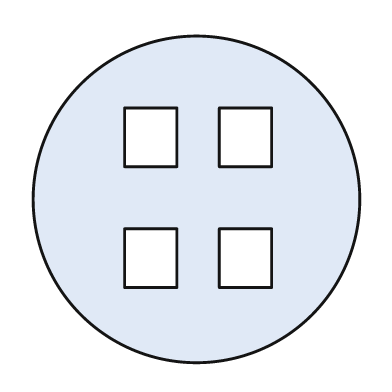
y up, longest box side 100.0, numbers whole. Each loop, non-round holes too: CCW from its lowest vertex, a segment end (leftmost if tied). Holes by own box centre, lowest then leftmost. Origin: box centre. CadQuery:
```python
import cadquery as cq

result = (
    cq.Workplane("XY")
    .moveTo(0.0, 0.0)
    .circle(50.0)
    .moveTo(-22.0, -27.0)
    .lineTo(-6.0, -27.0)
    .lineTo(-6.0, -9.0)
    .lineTo(-22.0, -9.0)
    .close()
    .moveTo(7.0, -27.0)
    .lineTo(23.0, -27.0)
    .lineTo(23.0, -9.0)
    .lineTo(7.0, -9.0)
    .close()
    .moveTo(-22.0, 10.0)
    .lineTo(-6.0, 10.0)
    .lineTo(-6.0, 28.0)
    .lineTo(-22.0, 28.0)
    .close()
    .moveTo(7.0, 10.0)
    .lineTo(23.0, 10.0)
    .lineTo(23.0, 28.0)
    .lineTo(7.0, 28.0)
    .close()
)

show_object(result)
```